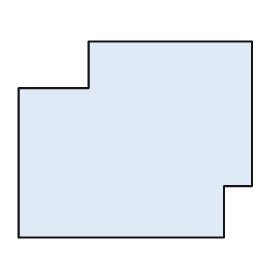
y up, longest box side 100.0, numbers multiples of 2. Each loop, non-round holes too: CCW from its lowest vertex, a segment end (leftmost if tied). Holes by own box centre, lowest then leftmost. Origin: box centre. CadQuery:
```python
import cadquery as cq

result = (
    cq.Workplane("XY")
    .moveTo(-50.0, -42.0)
    .lineTo(38.0, -42.0)
    .lineTo(38.0, -20.0)
    .lineTo(50.0, -20.0)
    .lineTo(50.0, 42.0)
    .lineTo(-20.0, 42.0)
    .lineTo(-20.0, 22.0)
    .lineTo(-50.0, 22.0)
    .close()
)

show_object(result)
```